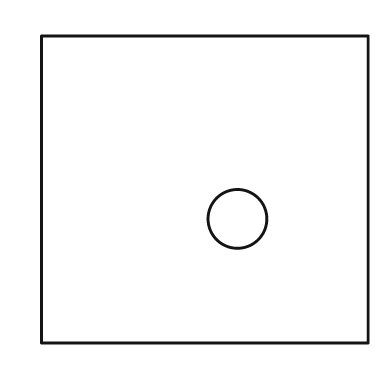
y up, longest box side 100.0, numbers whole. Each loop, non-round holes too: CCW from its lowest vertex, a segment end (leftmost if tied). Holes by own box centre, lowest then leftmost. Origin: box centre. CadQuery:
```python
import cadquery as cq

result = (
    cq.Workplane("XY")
    .moveTo(-50.0, -47.0)
    .lineTo(50.0, -47.0)
    .lineTo(50.0, 47.0)
    .lineTo(-50.0, 47.0)
    .close()
    .moveTo(10.0, -9.0)
    .circle(9.0)
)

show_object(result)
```